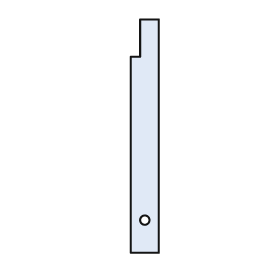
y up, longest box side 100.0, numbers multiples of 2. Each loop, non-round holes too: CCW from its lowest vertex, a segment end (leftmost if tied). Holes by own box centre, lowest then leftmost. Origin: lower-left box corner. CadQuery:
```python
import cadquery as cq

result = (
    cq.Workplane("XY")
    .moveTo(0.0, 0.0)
    .lineTo(12.0, 0.0)
    .lineTo(12.0, 100.0)
    .lineTo(4.0, 100.0)
    .lineTo(4.0, 84.0)
    .lineTo(0.0, 84.0)
    .close()
    .moveTo(6.0, 14.0)
    .circle(2.0)
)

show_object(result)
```